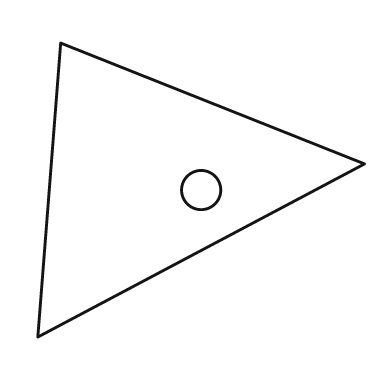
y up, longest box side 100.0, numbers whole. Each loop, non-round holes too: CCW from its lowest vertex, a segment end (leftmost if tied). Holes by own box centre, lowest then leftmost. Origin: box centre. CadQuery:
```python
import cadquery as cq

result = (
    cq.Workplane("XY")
    .moveTo(-50.0, -45.0)
    .lineTo(50.0, 8.0)
    .lineTo(-43.0, 45.0)
    .close()
    .moveTo(0.0, 0.0)
    .circle(6.0)
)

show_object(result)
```